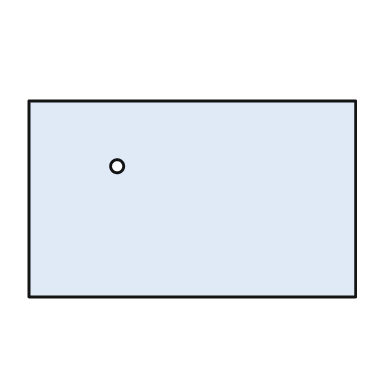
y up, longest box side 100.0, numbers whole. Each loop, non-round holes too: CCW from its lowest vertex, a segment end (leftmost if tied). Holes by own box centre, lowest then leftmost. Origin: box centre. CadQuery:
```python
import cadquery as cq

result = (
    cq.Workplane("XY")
    .moveTo(-50.0, -30.0)
    .lineTo(50.0, -30.0)
    .lineTo(50.0, 30.0)
    .lineTo(-50.0, 30.0)
    .close()
    .moveTo(-23.0, 10.0)
    .circle(2.0)
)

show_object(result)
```